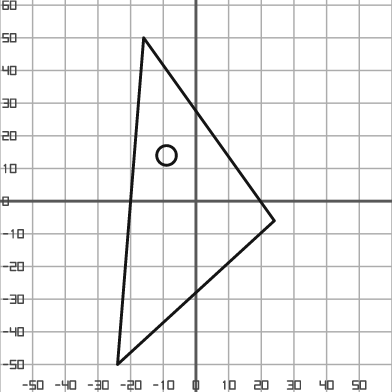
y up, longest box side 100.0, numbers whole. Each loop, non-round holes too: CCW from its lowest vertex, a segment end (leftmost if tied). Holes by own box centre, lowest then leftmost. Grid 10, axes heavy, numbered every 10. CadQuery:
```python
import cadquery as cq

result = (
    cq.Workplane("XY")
    .moveTo(-24.0, -50.0)
    .lineTo(24.0, -6.0)
    .lineTo(-16.0, 50.0)
    .close()
    .moveTo(-9.0, 14.0)
    .circle(3.0)
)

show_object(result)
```